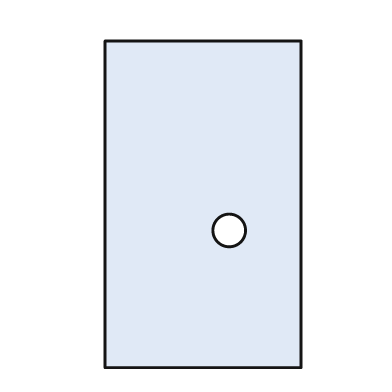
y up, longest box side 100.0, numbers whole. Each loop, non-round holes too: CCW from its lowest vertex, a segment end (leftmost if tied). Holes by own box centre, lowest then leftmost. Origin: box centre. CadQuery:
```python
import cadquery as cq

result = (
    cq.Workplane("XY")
    .moveTo(-30.0, -50.0)
    .lineTo(30.0, -50.0)
    .lineTo(30.0, 50.0)
    .lineTo(-30.0, 50.0)
    .close()
    .moveTo(8.0, -8.0)
    .circle(5.0)
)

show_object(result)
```